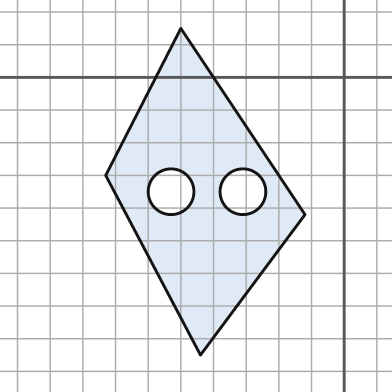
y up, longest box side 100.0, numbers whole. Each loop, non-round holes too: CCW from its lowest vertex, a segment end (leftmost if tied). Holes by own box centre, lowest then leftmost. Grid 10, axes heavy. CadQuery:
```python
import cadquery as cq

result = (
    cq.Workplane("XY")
    .moveTo(-44.0, -85.0)
    .lineTo(-12.0, -42.0)
    .lineTo(-50.0, 15.0)
    .lineTo(-73.0, -30.0)
    .close()
    .moveTo(-53.0, -35.0)
    .circle(7.0)
    .moveTo(-31.0, -35.0)
    .circle(7.0)
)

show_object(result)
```